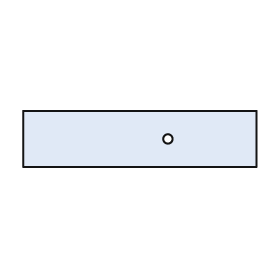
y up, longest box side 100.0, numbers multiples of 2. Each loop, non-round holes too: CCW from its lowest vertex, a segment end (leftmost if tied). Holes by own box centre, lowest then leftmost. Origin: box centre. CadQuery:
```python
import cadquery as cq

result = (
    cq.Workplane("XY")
    .moveTo(-50.0, -12.0)
    .lineTo(50.0, -12.0)
    .lineTo(50.0, 12.0)
    .lineTo(-50.0, 12.0)
    .close()
    .moveTo(12.0, 0.0)
    .circle(2.0)
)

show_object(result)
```